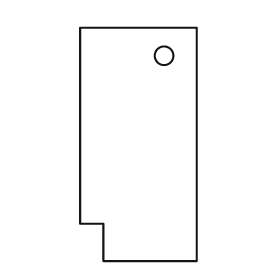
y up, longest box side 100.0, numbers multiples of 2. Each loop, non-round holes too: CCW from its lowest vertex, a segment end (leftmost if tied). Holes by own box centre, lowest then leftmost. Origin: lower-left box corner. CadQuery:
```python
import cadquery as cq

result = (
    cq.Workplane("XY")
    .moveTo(10.0, 0.0)
    .lineTo(50.0, 0.0)
    .lineTo(50.0, 100.0)
    .lineTo(0.0, 100.0)
    .lineTo(0.0, 16.0)
    .lineTo(10.0, 16.0)
    .close()
    .moveTo(36.0, 88.0)
    .circle(4.0)
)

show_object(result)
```